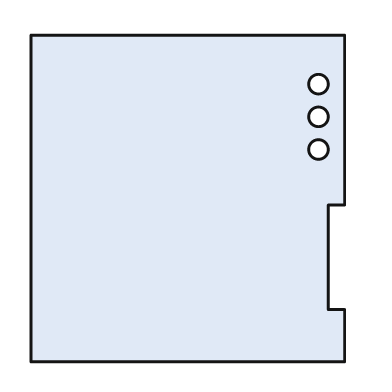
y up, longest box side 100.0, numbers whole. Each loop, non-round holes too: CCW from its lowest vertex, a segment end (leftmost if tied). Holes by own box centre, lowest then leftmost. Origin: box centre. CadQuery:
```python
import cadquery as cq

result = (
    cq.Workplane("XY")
    .moveTo(-48.0, -50.0)
    .lineTo(48.0, -50.0)
    .lineTo(48.0, -34.0)
    .lineTo(43.0, -34.0)
    .lineTo(43.0, -2.0)
    .lineTo(48.0, -2.0)
    .lineTo(48.0, 50.0)
    .lineTo(-48.0, 50.0)
    .close()
    .moveTo(40.0, 15.0)
    .circle(3.0)
    .moveTo(40.0, 25.0)
    .circle(3.0)
    .moveTo(40.0, 35.0)
    .circle(3.0)
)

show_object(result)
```